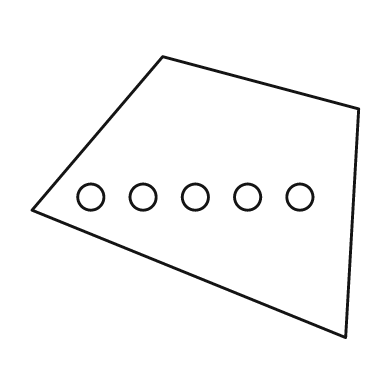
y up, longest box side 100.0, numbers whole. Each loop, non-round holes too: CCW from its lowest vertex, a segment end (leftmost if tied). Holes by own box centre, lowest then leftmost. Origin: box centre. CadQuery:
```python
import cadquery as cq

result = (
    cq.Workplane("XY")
    .moveTo(46.0, -43.0)
    .lineTo(50.0, 27.0)
    .lineTo(-10.0, 43.0)
    .lineTo(-50.0, -4.0)
    .close()
    .moveTo(-32.0, 0.0)
    .circle(4.0)
    .moveTo(-16.0, 0.0)
    .circle(4.0)
    .moveTo(0.0, 0.0)
    .circle(4.0)
    .moveTo(16.0, 0.0)
    .circle(4.0)
    .moveTo(32.0, 0.0)
    .circle(4.0)
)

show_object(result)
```